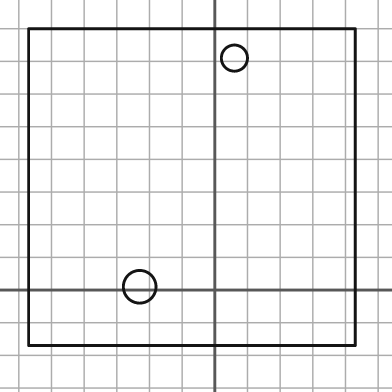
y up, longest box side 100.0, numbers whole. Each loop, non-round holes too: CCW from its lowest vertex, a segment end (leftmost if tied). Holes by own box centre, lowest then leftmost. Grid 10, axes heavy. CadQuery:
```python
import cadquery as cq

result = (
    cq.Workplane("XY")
    .moveTo(-57.0, -17.0)
    .lineTo(43.0, -17.0)
    .lineTo(43.0, 80.0)
    .lineTo(-57.0, 80.0)
    .close()
    .moveTo(-23.0, 1.0)
    .circle(5.0)
    .moveTo(6.0, 71.0)
    .circle(4.0)
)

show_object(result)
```